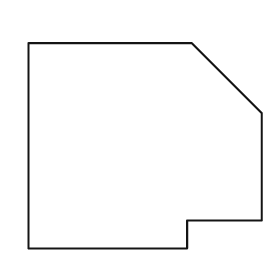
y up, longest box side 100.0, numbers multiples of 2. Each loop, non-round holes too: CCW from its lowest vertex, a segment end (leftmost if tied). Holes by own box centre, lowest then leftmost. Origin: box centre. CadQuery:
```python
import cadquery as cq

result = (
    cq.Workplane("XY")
    .moveTo(-50.0, -44.0)
    .lineTo(18.0, -44.0)
    .lineTo(18.0, -32.0)
    .lineTo(50.0, -32.0)
    .lineTo(50.0, 14.0)
    .lineTo(20.0, 44.0)
    .lineTo(-50.0, 44.0)
    .close()
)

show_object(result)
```